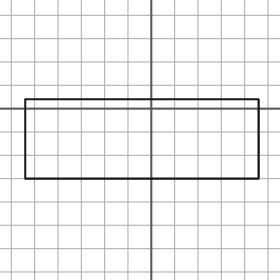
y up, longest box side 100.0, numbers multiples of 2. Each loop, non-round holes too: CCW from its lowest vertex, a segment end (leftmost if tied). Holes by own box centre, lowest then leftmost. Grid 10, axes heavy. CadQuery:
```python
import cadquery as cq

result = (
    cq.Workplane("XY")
    .moveTo(-54.0, -30.0)
    .lineTo(46.0, -30.0)
    .lineTo(46.0, 4.0)
    .lineTo(-54.0, 4.0)
    .close()
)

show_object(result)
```